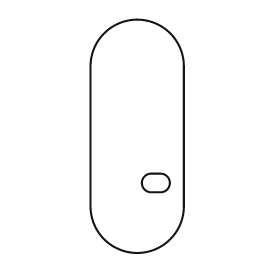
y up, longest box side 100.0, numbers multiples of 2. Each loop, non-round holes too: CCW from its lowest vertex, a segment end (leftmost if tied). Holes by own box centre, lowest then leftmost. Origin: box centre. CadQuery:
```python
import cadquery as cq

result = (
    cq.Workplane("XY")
    .moveTo(-20.0, -30.0)
    .threePointArc((0.0, -50.0), (20.0, -30.0))
    .lineTo(20.0, 30.0)
    .threePointArc((0.0, 50.0), (-20.0, 30.0))
    .close()
    .moveTo(6.0, -24.0)
    .lineTo(10.0, -24.0)
    .threePointArc((14.0, -20.0), (10.0, -16.0))
    .lineTo(6.0, -16.0)
    .threePointArc((2.0, -20.0), (6.0, -24.0))
    .close()
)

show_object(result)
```